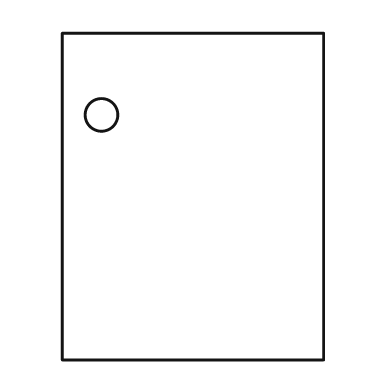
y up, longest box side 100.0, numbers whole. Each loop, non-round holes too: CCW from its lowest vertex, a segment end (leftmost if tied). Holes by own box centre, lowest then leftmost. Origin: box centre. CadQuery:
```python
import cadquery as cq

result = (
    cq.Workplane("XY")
    .moveTo(-40.0, -50.0)
    .lineTo(40.0, -50.0)
    .lineTo(40.0, 50.0)
    .lineTo(-40.0, 50.0)
    .close()
    .moveTo(-28.0, 25.0)
    .circle(5.0)
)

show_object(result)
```